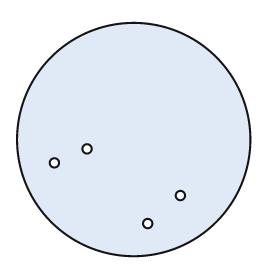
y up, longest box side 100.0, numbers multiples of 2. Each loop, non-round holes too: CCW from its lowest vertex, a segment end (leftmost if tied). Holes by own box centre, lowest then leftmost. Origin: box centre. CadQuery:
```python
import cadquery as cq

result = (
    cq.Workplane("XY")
    .moveTo(0.0, 0.0)
    .circle(50.0)
    .moveTo(6.0, -36.0)
    .circle(2.0)
    .moveTo(20.0, -24.0)
    .circle(2.0)
    .moveTo(-34.0, -10.0)
    .circle(2.0)
    .moveTo(-20.0, -4.0)
    .circle(2.0)
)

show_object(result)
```